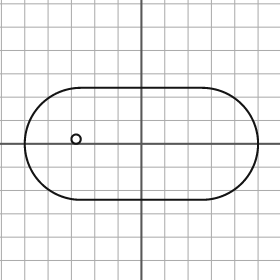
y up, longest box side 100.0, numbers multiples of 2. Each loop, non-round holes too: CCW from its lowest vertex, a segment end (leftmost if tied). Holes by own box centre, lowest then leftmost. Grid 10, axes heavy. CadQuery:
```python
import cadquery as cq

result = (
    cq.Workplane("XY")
    .moveTo(-26.0, -24.0)
    .lineTo(26.0, -24.0)
    .threePointArc((50.0, 0.0), (26.0, 24.0))
    .lineTo(-26.0, 24.0)
    .threePointArc((-50.0, 0.0), (-26.0, -24.0))
    .close()
    .moveTo(-28.0, 2.0)
    .circle(2.0)
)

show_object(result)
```